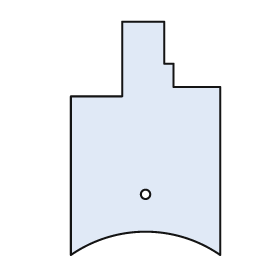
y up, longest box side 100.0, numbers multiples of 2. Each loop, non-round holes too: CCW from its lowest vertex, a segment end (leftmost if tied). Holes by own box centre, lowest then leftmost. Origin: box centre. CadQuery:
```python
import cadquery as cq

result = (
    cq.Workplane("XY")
    .moveTo(-32.0, -50.0)
    .threePointArc((0.0, -40.0), (32.0, -50.0))
    .lineTo(32.0, 22.0)
    .lineTo(12.0, 22.0)
    .lineTo(12.0, 32.0)
    .lineTo(8.0, 32.0)
    .lineTo(8.0, 50.0)
    .lineTo(-10.0, 50.0)
    .lineTo(-10.0, 18.0)
    .lineTo(-32.0, 18.0)
    .close()
    .moveTo(0.0, -24.0)
    .circle(2.0)
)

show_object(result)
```